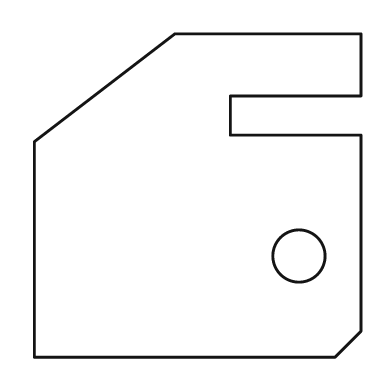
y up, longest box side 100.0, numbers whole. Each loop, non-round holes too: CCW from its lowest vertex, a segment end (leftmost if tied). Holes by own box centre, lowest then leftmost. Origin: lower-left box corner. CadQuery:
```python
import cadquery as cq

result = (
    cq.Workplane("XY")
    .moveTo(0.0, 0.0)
    .lineTo(92.0, 0.0)
    .lineTo(100.0, 8.0)
    .lineTo(100.0, 68.0)
    .lineTo(60.0, 68.0)
    .lineTo(60.0, 80.0)
    .lineTo(100.0, 80.0)
    .lineTo(100.0, 99.0)
    .lineTo(43.0, 99.0)
    .lineTo(0.0, 66.0)
    .close()
    .moveTo(81.0, 31.0)
    .circle(8.0)
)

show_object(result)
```